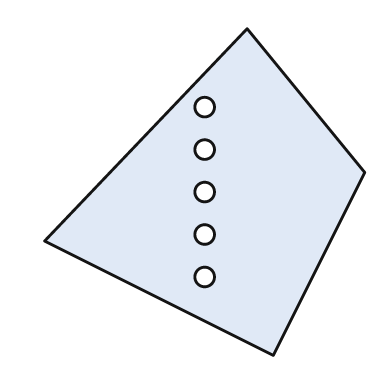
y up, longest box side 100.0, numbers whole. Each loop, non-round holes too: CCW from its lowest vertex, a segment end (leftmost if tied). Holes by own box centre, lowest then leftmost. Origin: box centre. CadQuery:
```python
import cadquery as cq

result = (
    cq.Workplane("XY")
    .moveTo(21.0, -50.0)
    .lineTo(49.0, 6.0)
    .lineTo(13.0, 50.0)
    .lineTo(-49.0, -15.0)
    .close()
    .moveTo(0.0, -26.0)
    .circle(3.0)
    .moveTo(0.0, -13.0)
    .circle(3.0)
    .moveTo(0.0, 0.0)
    .circle(3.0)
    .moveTo(0.0, 13.0)
    .circle(3.0)
    .moveTo(0.0, 26.0)
    .circle(3.0)
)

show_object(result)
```